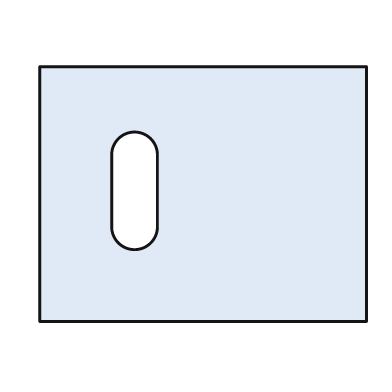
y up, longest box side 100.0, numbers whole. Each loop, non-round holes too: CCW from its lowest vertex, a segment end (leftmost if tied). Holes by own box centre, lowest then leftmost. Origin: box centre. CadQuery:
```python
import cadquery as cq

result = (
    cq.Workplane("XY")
    .moveTo(-50.0, -39.0)
    .lineTo(50.0, -39.0)
    .lineTo(50.0, 39.0)
    .lineTo(-50.0, 39.0)
    .close()
    .moveTo(-28.0, -10.0)
    .threePointArc((-21.0, -17.0), (-14.0, -10.0))
    .lineTo(-14.0, 12.0)
    .threePointArc((-21.0, 19.0), (-28.0, 12.0))
    .close()
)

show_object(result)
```